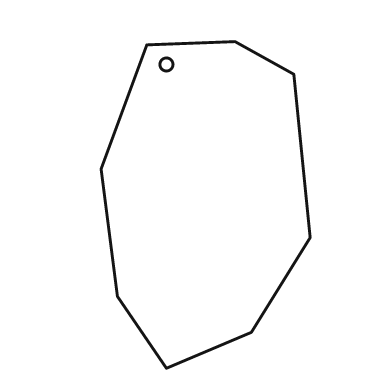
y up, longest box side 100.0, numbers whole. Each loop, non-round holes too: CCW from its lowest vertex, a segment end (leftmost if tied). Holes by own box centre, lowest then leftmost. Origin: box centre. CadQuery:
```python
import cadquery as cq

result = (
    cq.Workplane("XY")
    .moveTo(-12.0, -50.0)
    .lineTo(14.0, -39.0)
    .lineTo(32.0, -10.0)
    .lineTo(27.0, 40.0)
    .lineTo(9.0, 50.0)
    .lineTo(-18.0, 49.0)
    .lineTo(-32.0, 11.0)
    .lineTo(-27.0, -28.0)
    .close()
    .moveTo(-12.0, 43.0)
    .circle(2.0)
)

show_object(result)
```